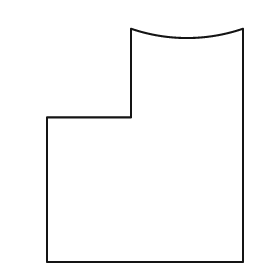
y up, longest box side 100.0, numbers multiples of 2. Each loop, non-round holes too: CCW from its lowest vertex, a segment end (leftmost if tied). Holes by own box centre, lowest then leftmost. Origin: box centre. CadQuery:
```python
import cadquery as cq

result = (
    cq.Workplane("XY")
    .moveTo(-42.0, -50.0)
    .lineTo(42.0, -50.0)
    .lineTo(42.0, 50.0)
    .threePointArc((18.0, 46.0), (-6.0, 50.0))
    .lineTo(-6.0, 12.0)
    .lineTo(-42.0, 12.0)
    .close()
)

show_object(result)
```